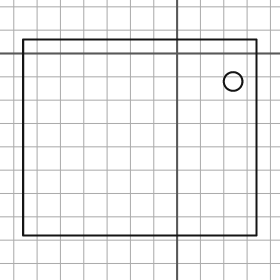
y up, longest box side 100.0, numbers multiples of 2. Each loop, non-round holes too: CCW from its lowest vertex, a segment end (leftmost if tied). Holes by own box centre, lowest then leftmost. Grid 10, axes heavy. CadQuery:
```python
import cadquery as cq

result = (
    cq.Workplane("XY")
    .moveTo(-66.0, -78.0)
    .lineTo(34.0, -78.0)
    .lineTo(34.0, 6.0)
    .lineTo(-66.0, 6.0)
    .close()
    .moveTo(24.0, -12.0)
    .circle(4.0)
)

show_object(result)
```